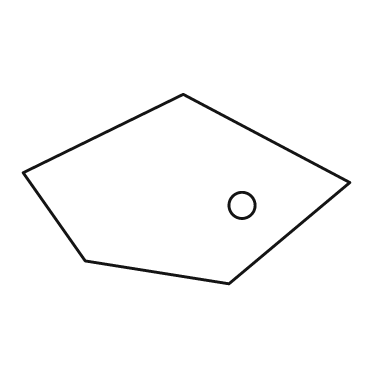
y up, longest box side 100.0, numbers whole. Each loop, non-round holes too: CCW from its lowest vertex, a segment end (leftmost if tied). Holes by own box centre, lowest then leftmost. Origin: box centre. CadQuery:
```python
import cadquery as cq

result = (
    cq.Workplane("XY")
    .moveTo(13.0, -29.0)
    .lineTo(50.0, 2.0)
    .lineTo(-1.0, 29.0)
    .lineTo(-50.0, 5.0)
    .lineTo(-31.0, -22.0)
    .close()
    .moveTo(17.0, -5.0)
    .circle(4.0)
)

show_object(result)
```